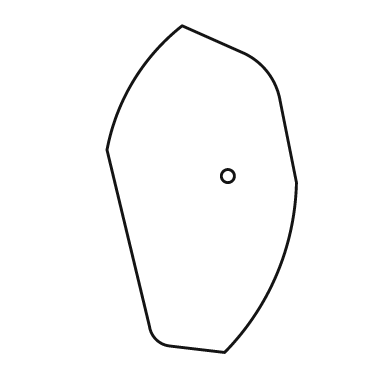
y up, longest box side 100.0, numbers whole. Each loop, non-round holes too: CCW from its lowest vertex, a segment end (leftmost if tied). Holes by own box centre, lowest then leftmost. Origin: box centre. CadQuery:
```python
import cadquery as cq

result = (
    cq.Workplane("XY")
    .moveTo(7.0, -50.0)
    .threePointArc((23.0, -26.0), (29.0, 2.0))
    .lineTo(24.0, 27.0)
    .threePointArc((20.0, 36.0), (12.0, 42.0))
    .lineTo(-6.0, 50.0)
    .threePointArc((-21.0, 33.0), (-29.0, 12.0))
    .lineTo(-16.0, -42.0)
    .threePointArc((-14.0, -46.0), (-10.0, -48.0))
    .close()
    .moveTo(8.0, 4.0)
    .circle(2.0)
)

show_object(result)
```